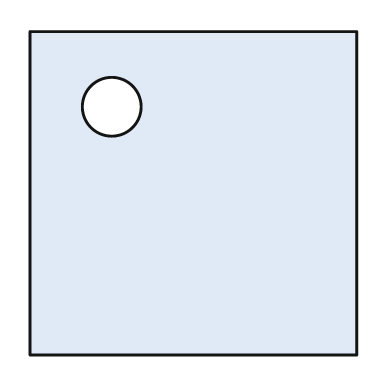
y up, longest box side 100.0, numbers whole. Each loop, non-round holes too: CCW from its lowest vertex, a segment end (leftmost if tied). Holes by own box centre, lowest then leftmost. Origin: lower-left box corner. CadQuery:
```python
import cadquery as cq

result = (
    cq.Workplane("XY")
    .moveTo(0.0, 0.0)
    .lineTo(100.0, 0.0)
    .lineTo(100.0, 99.0)
    .lineTo(0.0, 99.0)
    .close()
    .moveTo(25.0, 76.0)
    .circle(9.0)
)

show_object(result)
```